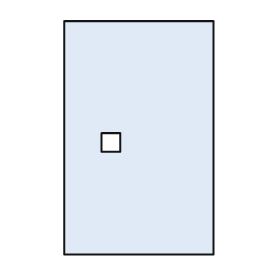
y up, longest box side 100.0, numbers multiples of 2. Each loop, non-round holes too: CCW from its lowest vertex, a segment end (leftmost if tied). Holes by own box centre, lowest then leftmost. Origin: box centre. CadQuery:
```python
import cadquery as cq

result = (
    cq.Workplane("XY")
    .moveTo(-32.0, -50.0)
    .lineTo(32.0, -50.0)
    .lineTo(32.0, 50.0)
    .lineTo(-32.0, 50.0)
    .close()
    .moveTo(-16.0, -6.0)
    .lineTo(-8.0, -6.0)
    .lineTo(-8.0, 2.0)
    .lineTo(-16.0, 2.0)
    .close()
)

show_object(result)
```